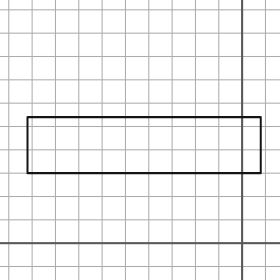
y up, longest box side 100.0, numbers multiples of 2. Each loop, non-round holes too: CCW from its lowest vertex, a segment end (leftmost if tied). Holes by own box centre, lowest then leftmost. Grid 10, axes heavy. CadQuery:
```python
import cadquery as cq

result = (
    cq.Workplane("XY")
    .moveTo(-92.0, 30.0)
    .lineTo(8.0, 30.0)
    .lineTo(8.0, 54.0)
    .lineTo(-92.0, 54.0)
    .close()
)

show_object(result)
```